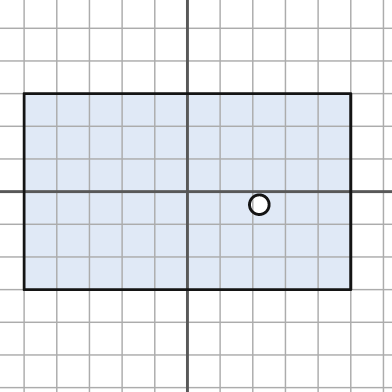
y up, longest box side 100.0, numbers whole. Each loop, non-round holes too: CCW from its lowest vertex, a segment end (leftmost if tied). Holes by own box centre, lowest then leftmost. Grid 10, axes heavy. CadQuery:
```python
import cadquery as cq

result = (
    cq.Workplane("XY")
    .moveTo(-50.0, -30.0)
    .lineTo(50.0, -30.0)
    .lineTo(50.0, 30.0)
    .lineTo(-50.0, 30.0)
    .close()
    .moveTo(22.0, -4.0)
    .circle(3.0)
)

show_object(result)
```